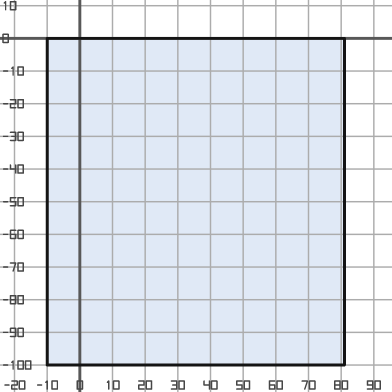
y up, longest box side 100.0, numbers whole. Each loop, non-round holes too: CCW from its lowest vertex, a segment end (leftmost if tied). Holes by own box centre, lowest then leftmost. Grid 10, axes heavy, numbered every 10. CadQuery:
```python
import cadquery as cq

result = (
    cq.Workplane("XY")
    .moveTo(-10.0, -100.0)
    .lineTo(81.0, -100.0)
    .lineTo(81.0, 0.0)
    .lineTo(-10.0, 0.0)
    .close()
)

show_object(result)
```